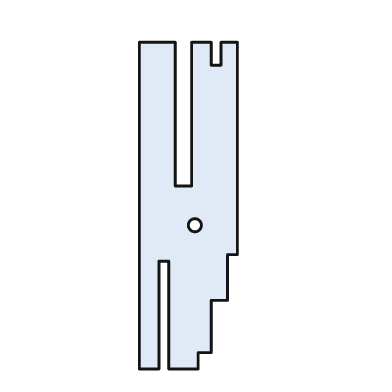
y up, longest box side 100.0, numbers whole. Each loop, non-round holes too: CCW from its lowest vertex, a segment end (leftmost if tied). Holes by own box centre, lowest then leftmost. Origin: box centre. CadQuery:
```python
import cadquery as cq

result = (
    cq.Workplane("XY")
    .moveTo(-15.0, -50.0)
    .lineTo(-9.0, -50.0)
    .lineTo(-9.0, -17.0)
    .lineTo(-6.0, -17.0)
    .lineTo(-6.0, -50.0)
    .lineTo(3.0, -50.0)
    .lineTo(3.0, -45.0)
    .lineTo(7.0, -45.0)
    .lineTo(7.0, -29.0)
    .lineTo(12.0, -29.0)
    .lineTo(12.0, -15.0)
    .lineTo(15.0, -15.0)
    .lineTo(15.0, 50.0)
    .lineTo(10.0, 50.0)
    .lineTo(10.0, 43.0)
    .lineTo(7.0, 43.0)
    .lineTo(7.0, 50.0)
    .lineTo(1.0, 50.0)
    .lineTo(1.0, 6.0)
    .lineTo(-4.0, 6.0)
    .lineTo(-4.0, 50.0)
    .lineTo(-15.0, 50.0)
    .close()
    .moveTo(2.0, -6.0)
    .circle(2.0)
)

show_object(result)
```